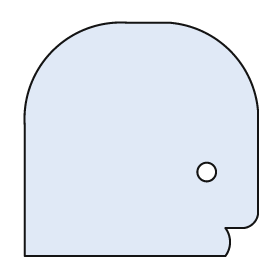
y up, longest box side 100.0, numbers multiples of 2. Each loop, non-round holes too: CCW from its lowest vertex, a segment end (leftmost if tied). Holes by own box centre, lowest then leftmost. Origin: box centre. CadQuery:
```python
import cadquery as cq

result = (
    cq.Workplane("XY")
    .moveTo(-50.0, -50.0)
    .lineTo(36.0, -50.0)
    .threePointArc((38.0, -44.0), (36.0, -38.0))
    .lineTo(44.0, -38.0)
    .threePointArc((48.0, -36.0), (50.0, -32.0))
    .lineTo(50.0, 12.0)
    .threePointArc((38.0, 38.0), (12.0, 50.0))
    .lineTo(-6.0, 50.0)
    .threePointArc((-38.0, 38.0), (-50.0, 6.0))
    .close()
    .moveTo(28.0, -14.0)
    .circle(4.0)
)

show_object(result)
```